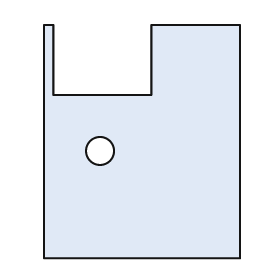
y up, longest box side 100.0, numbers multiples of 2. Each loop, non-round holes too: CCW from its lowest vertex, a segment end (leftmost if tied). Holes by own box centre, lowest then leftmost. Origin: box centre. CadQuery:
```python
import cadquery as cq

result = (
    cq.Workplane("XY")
    .moveTo(-42.0, -50.0)
    .lineTo(42.0, -50.0)
    .lineTo(42.0, 50.0)
    .lineTo(4.0, 50.0)
    .lineTo(4.0, 20.0)
    .lineTo(-38.0, 20.0)
    .lineTo(-38.0, 50.0)
    .lineTo(-42.0, 50.0)
    .close()
    .moveTo(-18.0, -4.0)
    .circle(6.0)
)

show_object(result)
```